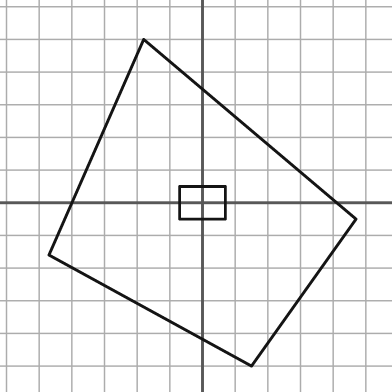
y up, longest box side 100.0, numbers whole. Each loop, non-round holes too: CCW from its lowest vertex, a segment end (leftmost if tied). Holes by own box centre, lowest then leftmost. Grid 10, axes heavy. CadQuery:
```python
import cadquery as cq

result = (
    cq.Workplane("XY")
    .moveTo(15.0, -50.0)
    .lineTo(47.0, -5.0)
    .lineTo(-18.0, 50.0)
    .lineTo(-47.0, -16.0)
    .close()
    .moveTo(-7.0, -5.0)
    .lineTo(7.0, -5.0)
    .lineTo(7.0, 5.0)
    .lineTo(-7.0, 5.0)
    .close()
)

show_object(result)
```